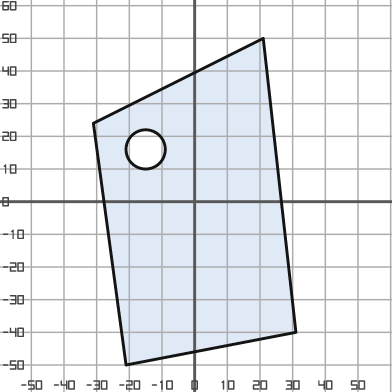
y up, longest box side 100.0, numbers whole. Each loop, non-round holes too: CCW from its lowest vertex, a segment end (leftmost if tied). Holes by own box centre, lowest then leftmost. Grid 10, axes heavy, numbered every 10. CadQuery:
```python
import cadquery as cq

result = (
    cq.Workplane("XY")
    .moveTo(-21.0, -50.0)
    .lineTo(31.0, -40.0)
    .lineTo(21.0, 50.0)
    .lineTo(-31.0, 24.0)
    .close()
    .moveTo(-15.0, 16.0)
    .circle(6.0)
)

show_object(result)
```